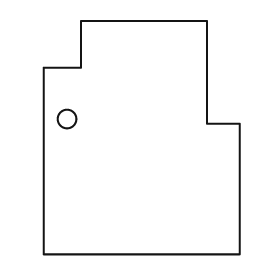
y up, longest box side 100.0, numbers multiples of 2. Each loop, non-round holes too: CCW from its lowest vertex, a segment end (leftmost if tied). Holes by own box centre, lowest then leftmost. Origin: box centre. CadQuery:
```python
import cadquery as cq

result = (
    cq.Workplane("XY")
    .moveTo(-42.0, -50.0)
    .lineTo(42.0, -50.0)
    .lineTo(42.0, 6.0)
    .lineTo(28.0, 6.0)
    .lineTo(28.0, 50.0)
    .lineTo(-26.0, 50.0)
    .lineTo(-26.0, 30.0)
    .lineTo(-42.0, 30.0)
    .close()
    .moveTo(-32.0, 8.0)
    .circle(4.0)
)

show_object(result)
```